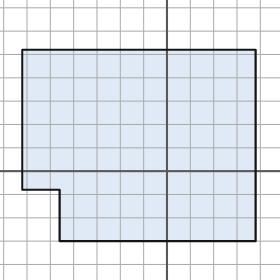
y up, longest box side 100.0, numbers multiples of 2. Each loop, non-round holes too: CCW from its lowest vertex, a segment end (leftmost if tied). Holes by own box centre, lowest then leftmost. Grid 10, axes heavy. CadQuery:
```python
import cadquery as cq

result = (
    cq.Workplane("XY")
    .moveTo(-46.0, -30.0)
    .lineTo(38.0, -30.0)
    .lineTo(38.0, 52.0)
    .lineTo(-62.0, 52.0)
    .lineTo(-62.0, -8.0)
    .lineTo(-46.0, -8.0)
    .close()
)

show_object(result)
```